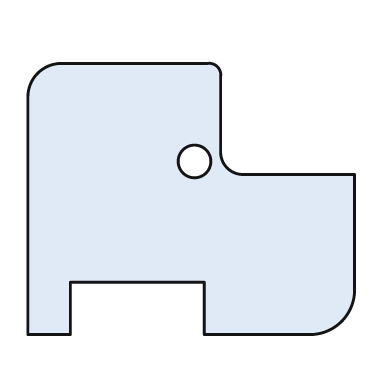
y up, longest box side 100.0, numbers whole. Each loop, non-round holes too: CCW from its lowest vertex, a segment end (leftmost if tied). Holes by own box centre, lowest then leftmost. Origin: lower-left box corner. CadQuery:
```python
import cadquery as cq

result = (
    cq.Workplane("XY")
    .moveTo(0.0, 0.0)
    .lineTo(13.0, 0.0)
    .lineTo(13.0, 16.0)
    .lineTo(54.0, 16.0)
    .lineTo(54.0, 0.0)
    .lineTo(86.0, 0.0)
    .threePointArc((96.0, 4.0), (100.0, 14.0))
    .lineTo(100.0, 49.0)
    .lineTo(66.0, 49.0)
    .threePointArc((61.0, 51.0), (59.0, 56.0))
    .lineTo(59.0, 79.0)
    .threePointArc((58.0, 82.0), (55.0, 83.0))
    .lineTo(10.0, 83.0)
    .threePointArc((3.0, 80.0), (0.0, 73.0))
    .close()
    .moveTo(51.0, 53.0)
    .circle(5.0)
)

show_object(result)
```